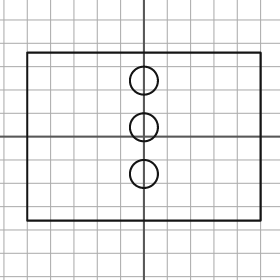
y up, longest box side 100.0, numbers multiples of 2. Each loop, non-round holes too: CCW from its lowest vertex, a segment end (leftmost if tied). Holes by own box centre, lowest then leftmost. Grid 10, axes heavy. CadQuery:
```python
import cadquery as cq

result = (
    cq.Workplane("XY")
    .moveTo(-50.0, -36.0)
    .lineTo(50.0, -36.0)
    .lineTo(50.0, 36.0)
    .lineTo(-50.0, 36.0)
    .close()
    .moveTo(0.0, -16.0)
    .circle(6.0)
    .moveTo(0.0, 4.0)
    .circle(6.0)
    .moveTo(0.0, 24.0)
    .circle(6.0)
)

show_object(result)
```